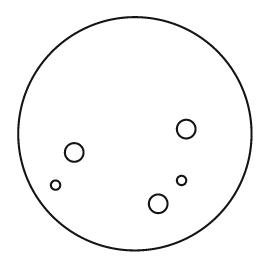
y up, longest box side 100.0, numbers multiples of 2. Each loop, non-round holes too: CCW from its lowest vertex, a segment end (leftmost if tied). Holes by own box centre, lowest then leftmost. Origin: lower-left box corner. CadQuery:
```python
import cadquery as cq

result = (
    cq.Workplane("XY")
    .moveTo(50.0, 50.0)
    .circle(50.0)
    .moveTo(60.0, 20.0)
    .circle(4.0)
    .moveTo(16.0, 28.0)
    .circle(2.0)
    .moveTo(70.0, 30.0)
    .circle(2.0)
    .moveTo(24.0, 42.0)
    .circle(4.0)
    .moveTo(72.0, 52.0)
    .circle(4.0)
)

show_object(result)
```